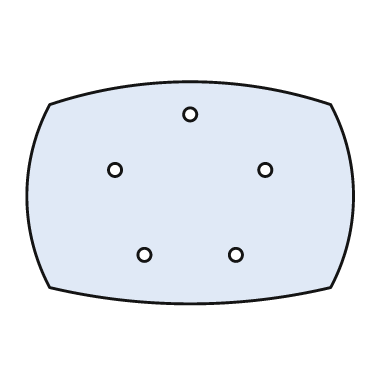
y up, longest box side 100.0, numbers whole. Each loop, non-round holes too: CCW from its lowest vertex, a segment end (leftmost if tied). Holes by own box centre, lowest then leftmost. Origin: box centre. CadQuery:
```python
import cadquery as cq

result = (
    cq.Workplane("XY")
    .moveTo(-43.0, -29.0)
    .threePointArc((0.0, -34.0), (43.0, -29.0))
    .threePointArc((50.0, -1.0), (43.0, 27.0))
    .threePointArc((0.0, 34.0), (-43.0, 27.0))
    .threePointArc((-50.0, -1.0), (-43.0, -29.0))
    .close()
    .moveTo(-14.0, -19.0)
    .circle(2.0)
    .moveTo(14.0, -19.0)
    .circle(2.0)
    .moveTo(-23.0, 7.0)
    .circle(2.0)
    .moveTo(23.0, 7.0)
    .circle(2.0)
    .moveTo(0.0, 24.0)
    .circle(2.0)
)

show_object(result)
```